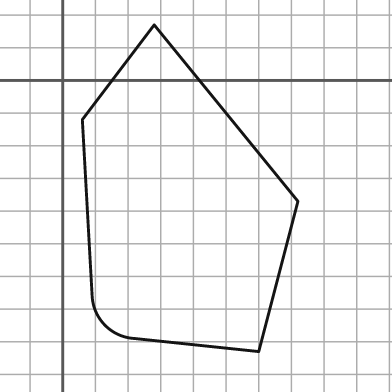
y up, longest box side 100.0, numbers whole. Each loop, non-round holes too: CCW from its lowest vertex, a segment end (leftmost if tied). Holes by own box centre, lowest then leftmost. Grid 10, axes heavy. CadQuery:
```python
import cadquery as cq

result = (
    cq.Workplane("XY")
    .moveTo(60.0, -83.0)
    .lineTo(72.0, -37.0)
    .lineTo(28.0, 17.0)
    .lineTo(6.0, -12.0)
    .lineTo(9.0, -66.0)
    .threePointArc((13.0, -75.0), (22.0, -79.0))
    .close()
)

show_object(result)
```